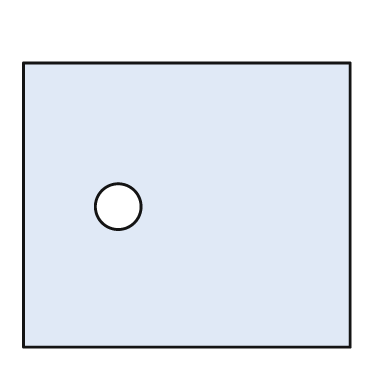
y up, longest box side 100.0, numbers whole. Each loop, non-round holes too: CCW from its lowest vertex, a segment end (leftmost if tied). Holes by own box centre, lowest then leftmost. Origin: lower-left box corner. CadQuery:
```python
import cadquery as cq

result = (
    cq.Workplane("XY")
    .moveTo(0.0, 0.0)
    .lineTo(100.0, 0.0)
    .lineTo(100.0, 87.0)
    .lineTo(0.0, 87.0)
    .close()
    .moveTo(29.0, 43.0)
    .circle(7.0)
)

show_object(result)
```